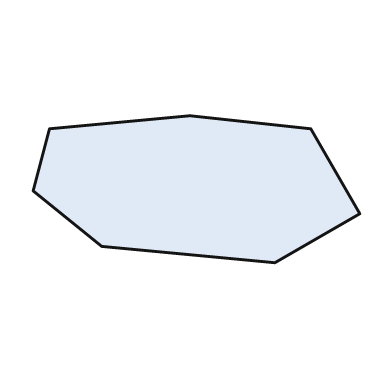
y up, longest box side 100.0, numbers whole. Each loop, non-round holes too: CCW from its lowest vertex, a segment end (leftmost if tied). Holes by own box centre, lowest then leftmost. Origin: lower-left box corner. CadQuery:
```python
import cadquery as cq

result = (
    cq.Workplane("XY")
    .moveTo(74.0, 0.0)
    .lineTo(100.0, 15.0)
    .lineTo(85.0, 41.0)
    .lineTo(48.0, 45.0)
    .lineTo(5.0, 41.0)
    .lineTo(0.0, 22.0)
    .lineTo(21.0, 5.0)
    .close()
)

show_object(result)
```